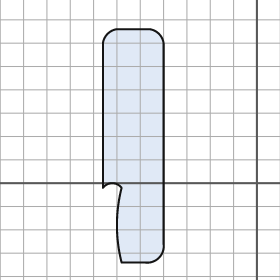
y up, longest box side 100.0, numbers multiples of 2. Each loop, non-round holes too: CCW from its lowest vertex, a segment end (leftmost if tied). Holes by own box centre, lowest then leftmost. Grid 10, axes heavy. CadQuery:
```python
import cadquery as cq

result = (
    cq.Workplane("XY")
    .moveTo(-58.0, -34.0)
    .lineTo(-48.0, -34.0)
    .threePointArc((-42.0, -32.0), (-40.0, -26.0))
    .lineTo(-40.0, 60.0)
    .threePointArc((-42.0, 64.0), (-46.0, 66.0))
    .lineTo(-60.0, 66.0)
    .threePointArc((-64.0, 64.0), (-66.0, 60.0))
    .lineTo(-66.0, -2.0)
    .threePointArc((-62.0, 0.0), (-58.0, -2.0))
    .threePointArc((-60.0, -18.0), (-58.0, -34.0))
    .close()
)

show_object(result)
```